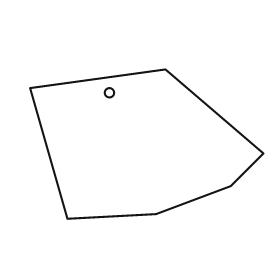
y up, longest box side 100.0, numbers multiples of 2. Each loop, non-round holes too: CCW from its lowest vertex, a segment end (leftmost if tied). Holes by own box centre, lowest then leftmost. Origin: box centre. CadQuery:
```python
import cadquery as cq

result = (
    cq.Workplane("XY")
    .moveTo(-34.0, -32.0)
    .lineTo(4.0, -30.0)
    .lineTo(36.0, -18.0)
    .lineTo(50.0, -4.0)
    .lineTo(8.0, 32.0)
    .lineTo(-50.0, 24.0)
    .close()
    .moveTo(-16.0, 22.0)
    .circle(2.0)
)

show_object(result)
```